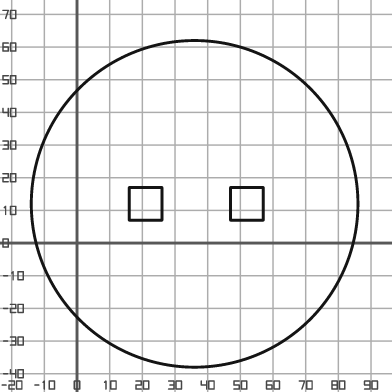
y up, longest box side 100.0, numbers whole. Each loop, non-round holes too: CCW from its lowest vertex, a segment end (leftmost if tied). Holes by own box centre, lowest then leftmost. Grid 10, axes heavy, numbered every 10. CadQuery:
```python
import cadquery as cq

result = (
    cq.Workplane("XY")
    .moveTo(36.0, 12.0)
    .circle(50.0)
    .moveTo(16.0, 7.0)
    .lineTo(26.0, 7.0)
    .lineTo(26.0, 17.0)
    .lineTo(16.0, 17.0)
    .close()
    .moveTo(47.0, 7.0)
    .lineTo(57.0, 7.0)
    .lineTo(57.0, 17.0)
    .lineTo(47.0, 17.0)
    .close()
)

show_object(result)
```